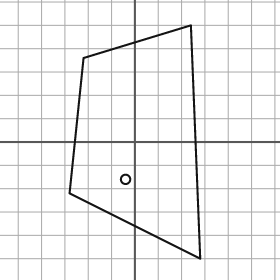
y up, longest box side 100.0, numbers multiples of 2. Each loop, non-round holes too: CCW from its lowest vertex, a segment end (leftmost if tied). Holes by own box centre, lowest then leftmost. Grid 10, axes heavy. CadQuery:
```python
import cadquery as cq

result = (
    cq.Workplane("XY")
    .moveTo(28.0, -50.0)
    .lineTo(24.0, 50.0)
    .lineTo(-22.0, 36.0)
    .lineTo(-28.0, -22.0)
    .close()
    .moveTo(-4.0, -16.0)
    .circle(2.0)
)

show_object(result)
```